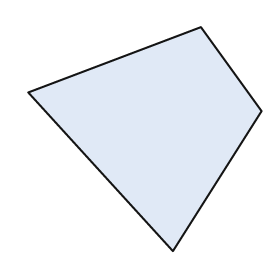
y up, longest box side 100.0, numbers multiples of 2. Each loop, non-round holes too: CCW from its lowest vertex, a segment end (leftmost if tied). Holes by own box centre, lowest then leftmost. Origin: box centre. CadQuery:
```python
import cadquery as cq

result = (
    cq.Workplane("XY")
    .moveTo(12.0, -48.0)
    .lineTo(50.0, 12.0)
    .lineTo(24.0, 48.0)
    .lineTo(-50.0, 20.0)
    .close()
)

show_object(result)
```